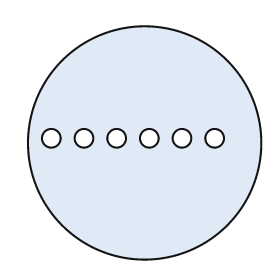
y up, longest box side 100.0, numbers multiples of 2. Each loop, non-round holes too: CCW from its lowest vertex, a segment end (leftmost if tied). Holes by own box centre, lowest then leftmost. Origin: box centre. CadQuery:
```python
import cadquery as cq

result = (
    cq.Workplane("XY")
    .moveTo(0.0, 0.0)
    .circle(50.0)
    .moveTo(-40.0, 2.0)
    .circle(4.0)
    .moveTo(-26.0, 2.0)
    .circle(4.0)
    .moveTo(-12.0, 2.0)
    .circle(4.0)
    .moveTo(2.0, 2.0)
    .circle(4.0)
    .moveTo(16.0, 2.0)
    .circle(4.0)
    .moveTo(30.0, 2.0)
    .circle(4.0)
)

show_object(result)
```